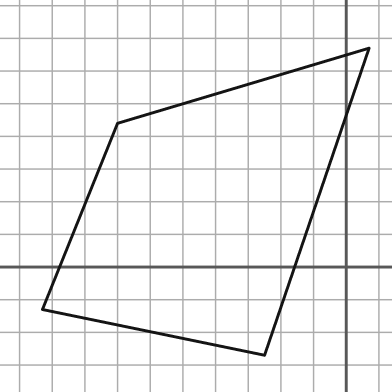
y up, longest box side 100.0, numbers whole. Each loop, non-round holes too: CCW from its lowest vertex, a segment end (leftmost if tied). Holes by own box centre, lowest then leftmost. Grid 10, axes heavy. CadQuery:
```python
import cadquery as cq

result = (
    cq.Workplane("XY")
    .moveTo(-25.0, -27.0)
    .lineTo(7.0, 67.0)
    .lineTo(-70.0, 44.0)
    .lineTo(-93.0, -13.0)
    .close()
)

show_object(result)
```